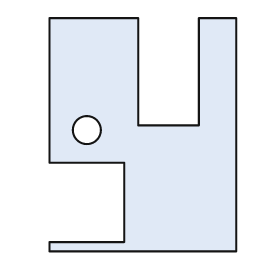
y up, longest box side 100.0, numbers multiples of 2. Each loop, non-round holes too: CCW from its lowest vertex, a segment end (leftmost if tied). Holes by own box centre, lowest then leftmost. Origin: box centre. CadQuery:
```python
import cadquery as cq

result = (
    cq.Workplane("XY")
    .moveTo(-40.0, -50.0)
    .lineTo(40.0, -50.0)
    .lineTo(40.0, 50.0)
    .lineTo(24.0, 50.0)
    .lineTo(24.0, 4.0)
    .lineTo(-2.0, 4.0)
    .lineTo(-2.0, 50.0)
    .lineTo(-40.0, 50.0)
    .lineTo(-40.0, -12.0)
    .lineTo(-8.0, -12.0)
    .lineTo(-8.0, -46.0)
    .lineTo(-40.0, -46.0)
    .close()
    .moveTo(-24.0, 2.0)
    .circle(6.0)
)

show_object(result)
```